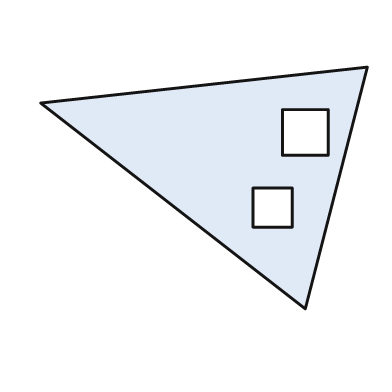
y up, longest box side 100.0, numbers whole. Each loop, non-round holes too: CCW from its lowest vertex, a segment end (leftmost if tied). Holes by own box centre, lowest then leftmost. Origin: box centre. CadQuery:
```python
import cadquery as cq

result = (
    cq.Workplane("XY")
    .moveTo(31.0, -37.0)
    .lineTo(50.0, 37.0)
    .lineTo(-50.0, 26.0)
    .close()
    .moveTo(15.0, -12.0)
    .lineTo(27.0, -12.0)
    .lineTo(27.0, 0.0)
    .lineTo(15.0, 0.0)
    .close()
    .moveTo(24.0, 10.0)
    .lineTo(38.0, 10.0)
    .lineTo(38.0, 24.0)
    .lineTo(24.0, 24.0)
    .close()
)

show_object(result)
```